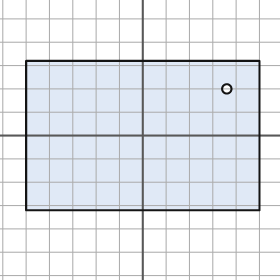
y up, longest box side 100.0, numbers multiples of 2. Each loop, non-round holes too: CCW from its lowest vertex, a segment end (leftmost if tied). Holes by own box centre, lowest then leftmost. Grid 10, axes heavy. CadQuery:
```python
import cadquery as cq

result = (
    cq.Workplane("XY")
    .moveTo(-50.0, -32.0)
    .lineTo(50.0, -32.0)
    .lineTo(50.0, 32.0)
    .lineTo(-50.0, 32.0)
    .close()
    .moveTo(36.0, 20.0)
    .circle(2.0)
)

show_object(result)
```